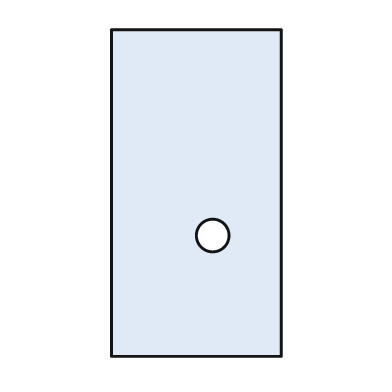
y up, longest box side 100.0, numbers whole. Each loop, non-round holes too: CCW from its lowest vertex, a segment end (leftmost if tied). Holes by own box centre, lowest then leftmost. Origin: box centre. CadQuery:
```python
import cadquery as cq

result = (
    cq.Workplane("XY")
    .moveTo(-26.0, -50.0)
    .lineTo(26.0, -50.0)
    .lineTo(26.0, 50.0)
    .lineTo(-26.0, 50.0)
    .close()
    .moveTo(5.0, -13.0)
    .circle(5.0)
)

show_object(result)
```